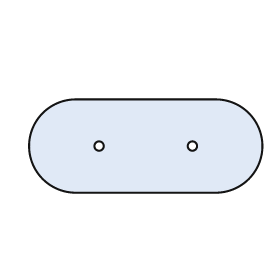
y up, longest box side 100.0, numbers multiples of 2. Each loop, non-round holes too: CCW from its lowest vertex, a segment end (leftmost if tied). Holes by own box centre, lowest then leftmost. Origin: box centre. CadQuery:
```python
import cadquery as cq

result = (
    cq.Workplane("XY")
    .moveTo(-30.0, -20.0)
    .lineTo(30.0, -20.0)
    .threePointArc((50.0, 0.0), (30.0, 20.0))
    .lineTo(-30.0, 20.0)
    .threePointArc((-50.0, 0.0), (-30.0, -20.0))
    .close()
    .moveTo(-20.0, 0.0)
    .circle(2.0)
    .moveTo(20.0, 0.0)
    .circle(2.0)
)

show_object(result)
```